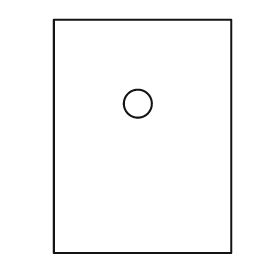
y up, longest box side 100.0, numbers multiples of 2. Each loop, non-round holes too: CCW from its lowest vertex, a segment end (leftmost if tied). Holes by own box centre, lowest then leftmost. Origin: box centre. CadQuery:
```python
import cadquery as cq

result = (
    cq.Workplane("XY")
    .moveTo(-38.0, -50.0)
    .lineTo(38.0, -50.0)
    .lineTo(38.0, 50.0)
    .lineTo(-38.0, 50.0)
    .close()
    .moveTo(-2.0, 14.0)
    .circle(6.0)
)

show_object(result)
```